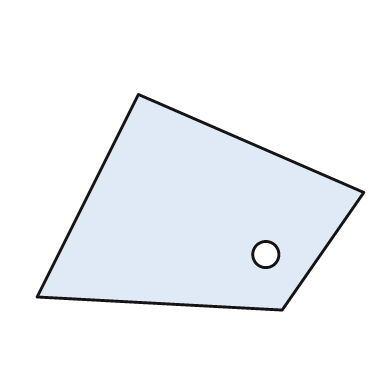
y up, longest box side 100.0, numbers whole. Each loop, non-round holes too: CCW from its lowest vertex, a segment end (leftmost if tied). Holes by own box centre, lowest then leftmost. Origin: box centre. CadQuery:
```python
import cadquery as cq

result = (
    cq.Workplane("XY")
    .moveTo(25.0, -33.0)
    .lineTo(50.0, 3.0)
    .lineTo(-19.0, 33.0)
    .lineTo(-50.0, -29.0)
    .close()
    .moveTo(20.0, -16.0)
    .circle(4.0)
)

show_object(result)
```